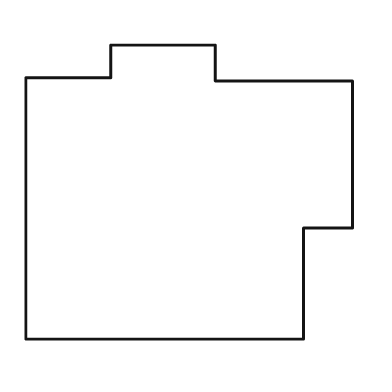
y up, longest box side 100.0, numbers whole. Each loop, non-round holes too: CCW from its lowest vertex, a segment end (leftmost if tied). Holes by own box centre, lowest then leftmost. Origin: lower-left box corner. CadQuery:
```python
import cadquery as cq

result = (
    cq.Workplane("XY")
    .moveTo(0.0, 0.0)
    .lineTo(85.0, 0.0)
    .lineTo(85.0, 34.0)
    .lineTo(100.0, 34.0)
    .lineTo(100.0, 79.0)
    .lineTo(58.0, 79.0)
    .lineTo(58.0, 90.0)
    .lineTo(26.0, 90.0)
    .lineTo(26.0, 80.0)
    .lineTo(0.0, 80.0)
    .close()
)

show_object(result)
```